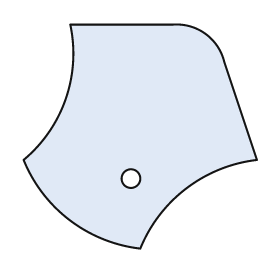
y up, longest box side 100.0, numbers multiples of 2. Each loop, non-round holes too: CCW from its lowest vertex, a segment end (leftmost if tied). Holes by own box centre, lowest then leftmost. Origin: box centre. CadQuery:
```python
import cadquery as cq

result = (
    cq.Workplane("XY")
    .moveTo(0.0, -48.0)
    .threePointArc((20.0, -22.0), (50.0, -10.0))
    .lineTo(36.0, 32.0)
    .threePointArc((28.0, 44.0), (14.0, 48.0))
    .lineTo(-30.0, 48.0)
    .threePointArc((-32.0, 16.0), (-50.0, -10.0))
    .threePointArc((-30.0, -36.0), (0.0, -48.0))
    .close()
    .moveTo(-4.0, -18.0)
    .circle(4.0)
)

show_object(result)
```